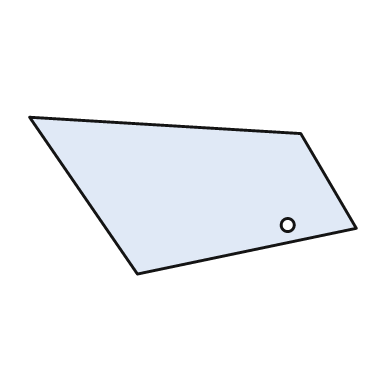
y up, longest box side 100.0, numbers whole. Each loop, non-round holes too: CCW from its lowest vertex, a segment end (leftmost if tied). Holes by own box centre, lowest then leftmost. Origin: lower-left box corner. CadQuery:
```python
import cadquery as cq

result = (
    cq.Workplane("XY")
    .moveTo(33.0, 0.0)
    .lineTo(100.0, 14.0)
    .lineTo(83.0, 43.0)
    .lineTo(0.0, 48.0)
    .close()
    .moveTo(79.0, 15.0)
    .circle(2.0)
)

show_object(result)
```